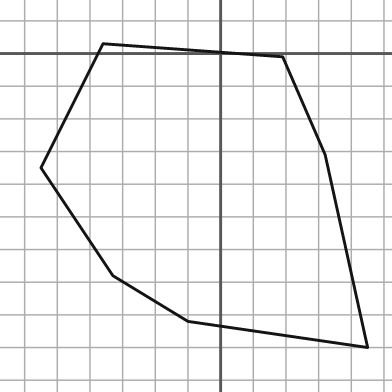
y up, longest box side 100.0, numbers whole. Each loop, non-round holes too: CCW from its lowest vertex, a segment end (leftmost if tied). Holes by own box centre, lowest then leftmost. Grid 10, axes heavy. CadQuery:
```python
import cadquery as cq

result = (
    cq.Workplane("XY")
    .moveTo(45.0, -90.0)
    .lineTo(32.0, -31.0)
    .lineTo(19.0, -1.0)
    .lineTo(-36.0, 3.0)
    .lineTo(-55.0, -35.0)
    .lineTo(-33.0, -68.0)
    .lineTo(-10.0, -82.0)
    .close()
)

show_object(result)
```